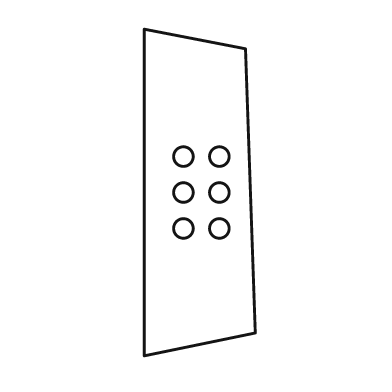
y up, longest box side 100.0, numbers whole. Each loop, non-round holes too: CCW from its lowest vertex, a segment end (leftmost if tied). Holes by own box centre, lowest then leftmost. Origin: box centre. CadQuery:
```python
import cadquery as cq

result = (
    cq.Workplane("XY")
    .moveTo(-17.0, -50.0)
    .lineTo(17.0, -43.0)
    .lineTo(14.0, 44.0)
    .lineTo(-17.0, 50.0)
    .close()
    .moveTo(-5.0, -11.0)
    .circle(3.0)
    .moveTo(6.0, -11.0)
    .circle(3.0)
    .moveTo(-5.0, 0.0)
    .circle(3.0)
    .moveTo(6.0, 0.0)
    .circle(3.0)
    .moveTo(-5.0, 11.0)
    .circle(3.0)
    .moveTo(6.0, 11.0)
    .circle(3.0)
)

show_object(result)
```